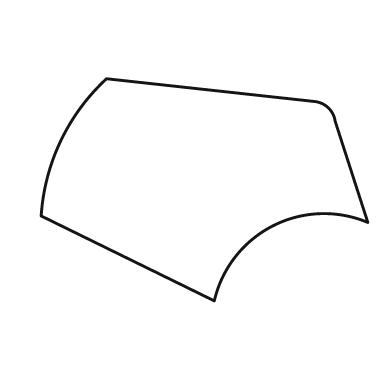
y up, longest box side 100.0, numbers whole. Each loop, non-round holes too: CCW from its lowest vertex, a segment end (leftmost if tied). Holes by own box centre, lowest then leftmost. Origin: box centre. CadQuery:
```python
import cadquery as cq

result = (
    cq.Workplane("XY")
    .moveTo(3.0, -34.0)
    .threePointArc((21.0, -11.0), (50.0, -10.0))
    .lineTo(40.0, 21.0)
    .threePointArc((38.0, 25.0), (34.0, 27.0))
    .lineTo(-30.0, 34.0)
    .threePointArc((-44.0, 15.0), (-50.0, -8.0))
    .close()
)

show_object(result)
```